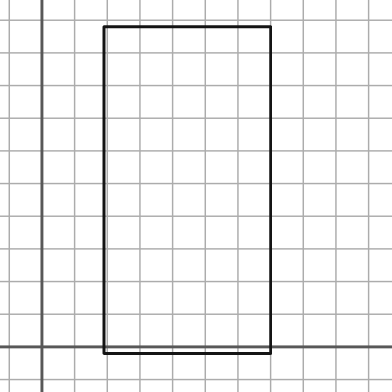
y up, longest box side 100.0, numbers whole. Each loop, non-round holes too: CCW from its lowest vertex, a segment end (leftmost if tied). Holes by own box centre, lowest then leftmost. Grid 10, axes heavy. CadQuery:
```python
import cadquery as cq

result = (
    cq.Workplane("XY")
    .moveTo(19.0, -2.0)
    .lineTo(70.0, -2.0)
    .lineTo(70.0, 98.0)
    .lineTo(19.0, 98.0)
    .close()
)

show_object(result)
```